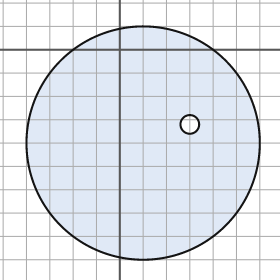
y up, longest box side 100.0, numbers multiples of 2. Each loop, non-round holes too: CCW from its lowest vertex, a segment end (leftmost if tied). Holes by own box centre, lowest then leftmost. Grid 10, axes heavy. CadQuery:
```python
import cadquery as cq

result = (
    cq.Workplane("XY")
    .moveTo(10.0, -40.0)
    .circle(50.0)
    .moveTo(30.0, -32.0)
    .circle(4.0)
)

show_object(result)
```